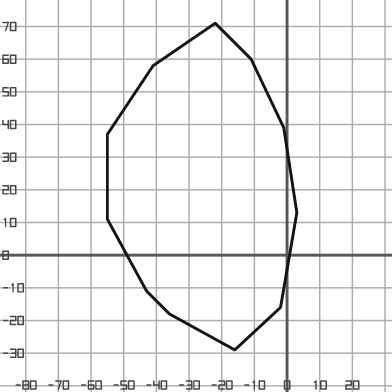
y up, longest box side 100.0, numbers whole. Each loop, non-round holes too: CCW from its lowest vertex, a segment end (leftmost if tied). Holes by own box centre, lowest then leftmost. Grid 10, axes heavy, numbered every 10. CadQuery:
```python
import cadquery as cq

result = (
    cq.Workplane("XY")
    .moveTo(-16.0, -29.0)
    .lineTo(-2.0, -16.0)
    .lineTo(3.0, 13.0)
    .lineTo(-1.0, 39.0)
    .lineTo(-11.0, 60.0)
    .lineTo(-22.0, 71.0)
    .lineTo(-41.0, 58.0)
    .lineTo(-55.0, 37.0)
    .lineTo(-55.0, 11.0)
    .lineTo(-43.0, -11.0)
    .lineTo(-36.0, -18.0)
    .close()
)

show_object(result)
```